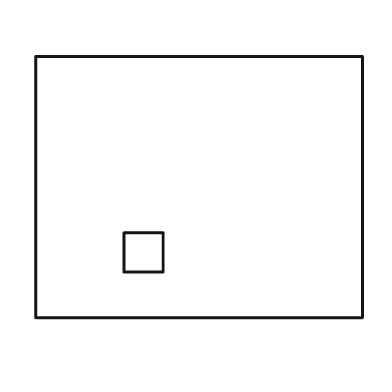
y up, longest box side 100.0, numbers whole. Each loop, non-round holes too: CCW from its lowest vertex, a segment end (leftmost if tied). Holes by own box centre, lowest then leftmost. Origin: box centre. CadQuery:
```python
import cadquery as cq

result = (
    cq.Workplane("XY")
    .moveTo(-50.0, -40.0)
    .lineTo(50.0, -40.0)
    .lineTo(50.0, 40.0)
    .lineTo(-50.0, 40.0)
    .close()
    .moveTo(-23.0, -26.0)
    .lineTo(-11.0, -26.0)
    .lineTo(-11.0, -14.0)
    .lineTo(-23.0, -14.0)
    .close()
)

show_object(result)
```